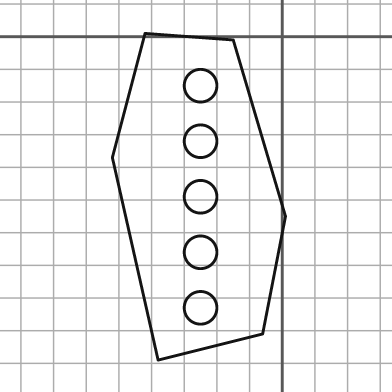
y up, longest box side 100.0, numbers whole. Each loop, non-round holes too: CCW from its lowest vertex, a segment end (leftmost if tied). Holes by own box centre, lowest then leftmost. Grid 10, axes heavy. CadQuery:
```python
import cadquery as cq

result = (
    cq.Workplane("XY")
    .moveTo(-38.0, -99.0)
    .lineTo(-6.0, -91.0)
    .lineTo(1.0, -55.0)
    .lineTo(-15.0, -1.0)
    .lineTo(-42.0, 1.0)
    .lineTo(-52.0, -37.0)
    .close()
    .moveTo(-25.0, -83.0)
    .circle(5.0)
    .moveTo(-25.0, -66.0)
    .circle(5.0)
    .moveTo(-25.0, -49.0)
    .circle(5.0)
    .moveTo(-25.0, -32.0)
    .circle(5.0)
    .moveTo(-25.0, -15.0)
    .circle(5.0)
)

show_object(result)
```